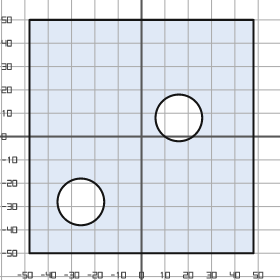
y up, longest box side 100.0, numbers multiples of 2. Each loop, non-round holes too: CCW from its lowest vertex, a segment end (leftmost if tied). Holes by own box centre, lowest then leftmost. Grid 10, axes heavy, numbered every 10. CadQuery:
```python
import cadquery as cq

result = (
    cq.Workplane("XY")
    .moveTo(-48.0, -50.0)
    .lineTo(48.0, -50.0)
    .lineTo(48.0, 50.0)
    .lineTo(-48.0, 50.0)
    .close()
    .moveTo(-26.0, -28.0)
    .circle(10.0)
    .moveTo(16.0, 8.0)
    .circle(10.0)
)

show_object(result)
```